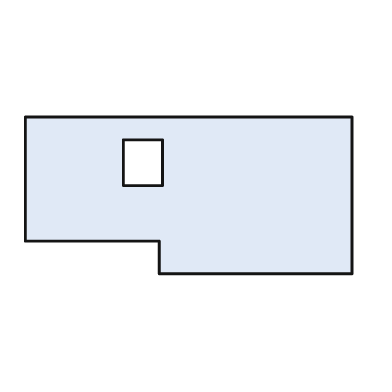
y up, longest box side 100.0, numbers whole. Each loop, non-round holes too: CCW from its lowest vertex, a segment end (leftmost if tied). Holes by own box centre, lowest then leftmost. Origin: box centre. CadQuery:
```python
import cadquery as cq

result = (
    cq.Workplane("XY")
    .moveTo(-9.0, -24.0)
    .lineTo(50.0, -24.0)
    .lineTo(50.0, 24.0)
    .lineTo(-50.0, 24.0)
    .lineTo(-50.0, -14.0)
    .lineTo(-9.0, -14.0)
    .close()
    .moveTo(-20.0, 3.0)
    .lineTo(-8.0, 3.0)
    .lineTo(-8.0, 17.0)
    .lineTo(-20.0, 17.0)
    .close()
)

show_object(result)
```